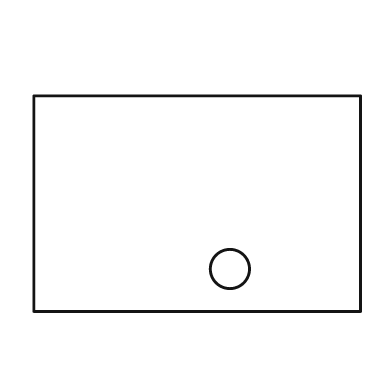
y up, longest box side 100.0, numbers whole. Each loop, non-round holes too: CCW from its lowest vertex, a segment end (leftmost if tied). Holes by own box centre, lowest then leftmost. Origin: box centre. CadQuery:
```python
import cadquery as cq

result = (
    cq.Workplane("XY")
    .moveTo(-50.0, -33.0)
    .lineTo(50.0, -33.0)
    .lineTo(50.0, 33.0)
    .lineTo(-50.0, 33.0)
    .close()
    .moveTo(10.0, -20.0)
    .circle(6.0)
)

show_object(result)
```